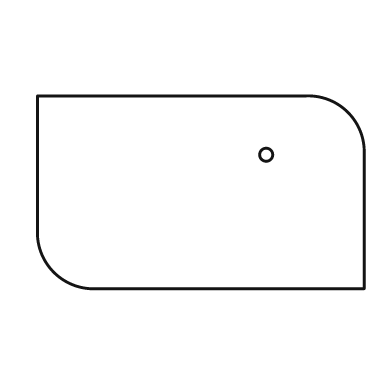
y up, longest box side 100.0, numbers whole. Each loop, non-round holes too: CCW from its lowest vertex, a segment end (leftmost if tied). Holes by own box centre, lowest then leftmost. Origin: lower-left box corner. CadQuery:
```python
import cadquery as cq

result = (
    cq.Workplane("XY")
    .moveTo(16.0, 0.0)
    .lineTo(100.0, 0.0)
    .lineTo(100.0, 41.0)
    .threePointArc((95.0, 54.0), (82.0, 59.0))
    .lineTo(0.0, 59.0)
    .lineTo(0.0, 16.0)
    .threePointArc((5.0, 5.0), (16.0, 0.0))
    .close()
    .moveTo(70.0, 41.0)
    .circle(2.0)
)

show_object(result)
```